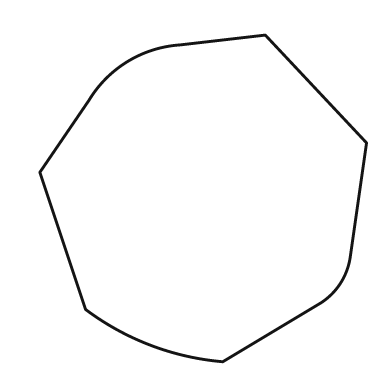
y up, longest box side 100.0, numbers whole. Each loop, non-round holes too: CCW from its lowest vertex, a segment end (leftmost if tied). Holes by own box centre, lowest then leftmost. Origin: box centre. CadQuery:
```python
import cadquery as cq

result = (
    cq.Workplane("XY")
    .moveTo(6.0, -50.0)
    .lineTo(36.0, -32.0)
    .threePointArc((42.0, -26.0), (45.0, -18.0))
    .lineTo(50.0, 17.0)
    .lineTo(19.0, 50.0)
    .lineTo(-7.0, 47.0)
    .threePointArc((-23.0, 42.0), (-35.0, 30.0))
    .lineTo(-50.0, 8.0)
    .lineTo(-36.0, -34.0)
    .threePointArc((-16.0, -45.0), (6.0, -50.0))
    .close()
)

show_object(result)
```